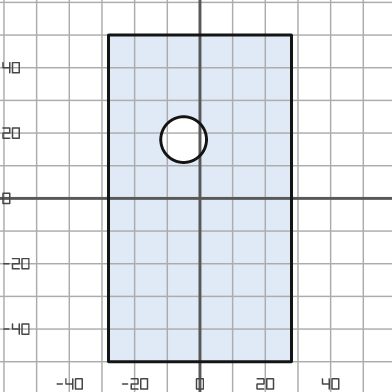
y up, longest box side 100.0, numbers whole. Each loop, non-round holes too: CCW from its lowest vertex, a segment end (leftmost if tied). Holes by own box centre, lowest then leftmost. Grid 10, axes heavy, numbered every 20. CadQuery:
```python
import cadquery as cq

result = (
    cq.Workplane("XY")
    .moveTo(-28.0, -50.0)
    .lineTo(28.0, -50.0)
    .lineTo(28.0, 50.0)
    .lineTo(-28.0, 50.0)
    .close()
    .moveTo(-5.0, 18.0)
    .circle(7.0)
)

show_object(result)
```